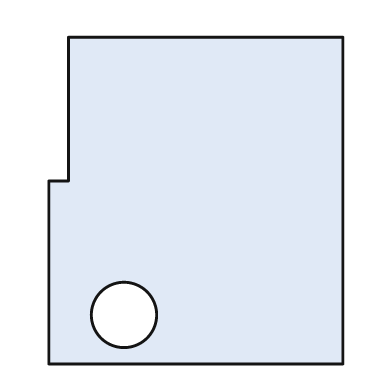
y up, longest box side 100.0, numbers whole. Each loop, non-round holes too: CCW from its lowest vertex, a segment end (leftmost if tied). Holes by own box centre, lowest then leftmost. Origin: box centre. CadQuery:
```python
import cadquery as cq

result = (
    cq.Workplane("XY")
    .moveTo(-45.0, -50.0)
    .lineTo(45.0, -50.0)
    .lineTo(45.0, 50.0)
    .lineTo(-39.0, 50.0)
    .lineTo(-39.0, 6.0)
    .lineTo(-45.0, 6.0)
    .close()
    .moveTo(-22.0, -35.0)
    .circle(10.0)
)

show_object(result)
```